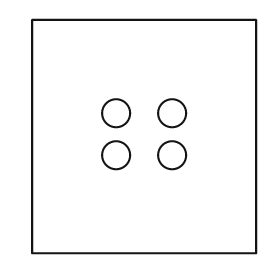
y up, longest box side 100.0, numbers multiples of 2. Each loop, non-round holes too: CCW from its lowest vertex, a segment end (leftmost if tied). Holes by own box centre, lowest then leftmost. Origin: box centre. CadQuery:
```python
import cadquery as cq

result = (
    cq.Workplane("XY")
    .moveTo(-48.0, -50.0)
    .lineTo(48.0, -50.0)
    .lineTo(48.0, 50.0)
    .lineTo(-48.0, 50.0)
    .close()
    .moveTo(-12.0, -8.0)
    .circle(6.0)
    .moveTo(12.0, -8.0)
    .circle(6.0)
    .moveTo(-12.0, 10.0)
    .circle(6.0)
    .moveTo(12.0, 10.0)
    .circle(6.0)
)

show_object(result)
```